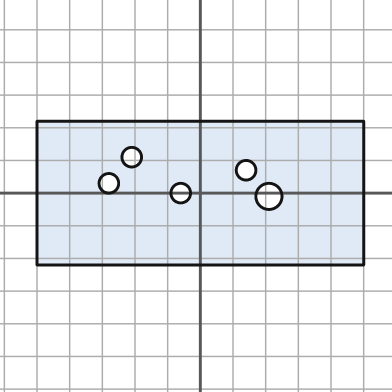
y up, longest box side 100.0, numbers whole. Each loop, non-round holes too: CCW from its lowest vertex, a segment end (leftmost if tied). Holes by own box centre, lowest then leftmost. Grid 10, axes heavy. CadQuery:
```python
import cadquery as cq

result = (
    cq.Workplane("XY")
    .moveTo(-50.0, -22.0)
    .lineTo(50.0, -22.0)
    .lineTo(50.0, 22.0)
    .lineTo(-50.0, 22.0)
    .close()
    .moveTo(21.0, -1.0)
    .circle(4.0)
    .moveTo(-6.0, 0.0)
    .circle(3.0)
    .moveTo(-28.0, 3.0)
    .circle(3.0)
    .moveTo(14.0, 7.0)
    .circle(3.0)
    .moveTo(-21.0, 11.0)
    .circle(3.0)
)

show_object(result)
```